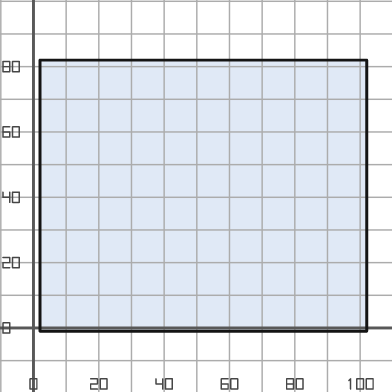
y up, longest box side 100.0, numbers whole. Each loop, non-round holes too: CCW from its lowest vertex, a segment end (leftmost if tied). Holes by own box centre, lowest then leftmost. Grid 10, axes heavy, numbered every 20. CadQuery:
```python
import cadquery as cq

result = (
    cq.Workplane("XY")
    .moveTo(2.0, -1.0)
    .lineTo(102.0, -1.0)
    .lineTo(102.0, 82.0)
    .lineTo(2.0, 82.0)
    .close()
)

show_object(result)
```